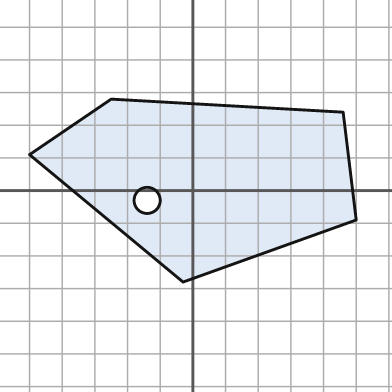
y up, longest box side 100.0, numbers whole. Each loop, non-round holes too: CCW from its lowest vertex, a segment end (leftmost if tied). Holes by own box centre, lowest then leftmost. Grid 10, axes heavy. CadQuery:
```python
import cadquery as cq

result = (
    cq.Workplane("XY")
    .moveTo(-3.0, -28.0)
    .lineTo(50.0, -9.0)
    .lineTo(46.0, 24.0)
    .lineTo(-25.0, 28.0)
    .lineTo(-50.0, 11.0)
    .close()
    .moveTo(-14.0, -3.0)
    .circle(4.0)
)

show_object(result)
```